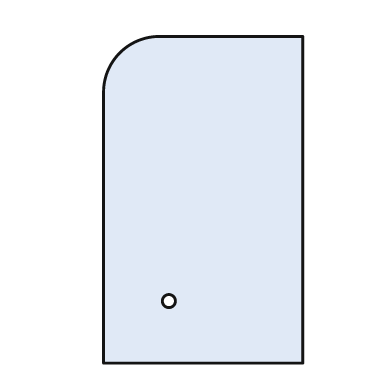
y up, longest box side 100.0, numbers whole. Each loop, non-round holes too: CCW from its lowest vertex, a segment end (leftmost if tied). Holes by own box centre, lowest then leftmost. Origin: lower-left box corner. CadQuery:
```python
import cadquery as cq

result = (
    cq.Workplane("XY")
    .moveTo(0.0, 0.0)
    .lineTo(61.0, 0.0)
    .lineTo(61.0, 100.0)
    .lineTo(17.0, 100.0)
    .threePointArc((5.0, 95.0), (0.0, 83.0))
    .close()
    .moveTo(20.0, 19.0)
    .circle(2.0)
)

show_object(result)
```